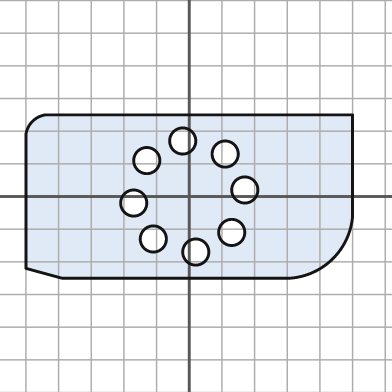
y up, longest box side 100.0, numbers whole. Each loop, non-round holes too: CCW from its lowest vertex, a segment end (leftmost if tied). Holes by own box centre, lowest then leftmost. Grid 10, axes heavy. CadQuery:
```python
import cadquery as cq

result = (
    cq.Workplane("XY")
    .moveTo(-39.0, -25.0)
    .lineTo(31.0, -25.0)
    .threePointArc((44.0, -19.0), (50.0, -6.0))
    .lineTo(50.0, 25.0)
    .lineTo(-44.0, 25.0)
    .threePointArc((-48.0, 23.0), (-50.0, 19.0))
    .lineTo(-50.0, -22.0)
    .close()
    .moveTo(2.0, -17.0)
    .circle(4.0)
    .moveTo(-11.0, -13.0)
    .circle(4.0)
    .moveTo(13.0, -11.0)
    .circle(4.0)
    .moveTo(-17.0, -2.0)
    .circle(4.0)
    .moveTo(17.0, 2.0)
    .circle(4.0)
    .moveTo(-13.0, 11.0)
    .circle(4.0)
    .moveTo(11.0, 13.0)
    .circle(4.0)
    .moveTo(-2.0, 17.0)
    .circle(4.0)
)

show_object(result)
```